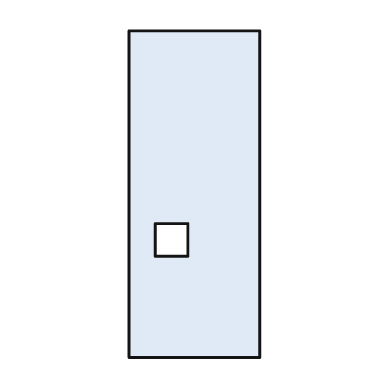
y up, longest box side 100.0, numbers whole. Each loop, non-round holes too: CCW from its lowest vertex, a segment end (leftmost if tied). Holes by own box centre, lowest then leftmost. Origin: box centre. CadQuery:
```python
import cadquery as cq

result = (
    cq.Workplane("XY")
    .moveTo(-20.0, -50.0)
    .lineTo(20.0, -50.0)
    .lineTo(20.0, 50.0)
    .lineTo(-20.0, 50.0)
    .close()
    .moveTo(-12.0, -19.0)
    .lineTo(-2.0, -19.0)
    .lineTo(-2.0, -9.0)
    .lineTo(-12.0, -9.0)
    .close()
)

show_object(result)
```